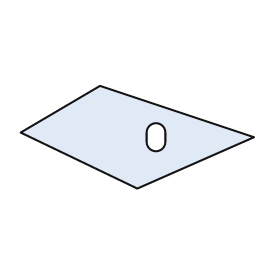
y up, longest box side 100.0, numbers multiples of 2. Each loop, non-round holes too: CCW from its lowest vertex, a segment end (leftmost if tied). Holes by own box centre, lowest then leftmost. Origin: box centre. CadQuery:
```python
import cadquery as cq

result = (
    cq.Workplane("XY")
    .moveTo(0.0, -22.0)
    .lineTo(50.0, 0.0)
    .lineTo(-16.0, 22.0)
    .lineTo(-50.0, 2.0)
    .close()
    .moveTo(4.0, -2.0)
    .threePointArc((8.0, -6.0), (12.0, -2.0))
    .lineTo(12.0, 2.0)
    .threePointArc((8.0, 6.0), (4.0, 2.0))
    .close()
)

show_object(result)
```